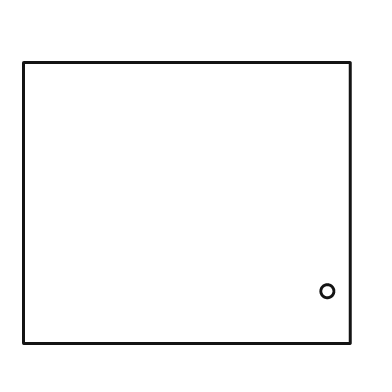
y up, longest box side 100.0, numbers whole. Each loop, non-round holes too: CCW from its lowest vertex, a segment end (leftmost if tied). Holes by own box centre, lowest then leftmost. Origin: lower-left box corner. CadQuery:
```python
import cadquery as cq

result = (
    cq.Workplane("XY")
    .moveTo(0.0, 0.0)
    .lineTo(100.0, 0.0)
    .lineTo(100.0, 86.0)
    .lineTo(0.0, 86.0)
    .close()
    .moveTo(93.0, 16.0)
    .circle(2.0)
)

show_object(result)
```